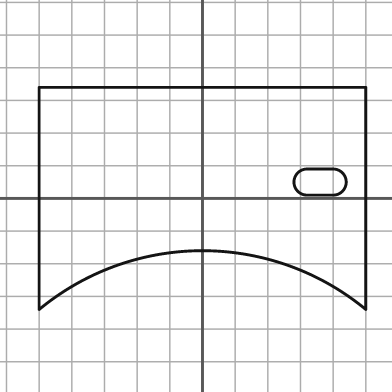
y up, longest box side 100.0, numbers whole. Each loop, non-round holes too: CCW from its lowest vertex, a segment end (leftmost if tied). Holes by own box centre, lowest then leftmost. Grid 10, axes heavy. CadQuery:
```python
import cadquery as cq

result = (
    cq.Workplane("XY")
    .moveTo(-50.0, -34.0)
    .threePointArc((0.0, -16.0), (50.0, -34.0))
    .lineTo(50.0, 34.0)
    .lineTo(-50.0, 34.0)
    .close()
    .moveTo(32.0, 1.0)
    .lineTo(40.0, 1.0)
    .threePointArc((44.0, 5.0), (40.0, 9.0))
    .lineTo(32.0, 9.0)
    .threePointArc((28.0, 5.0), (32.0, 1.0))
    .close()
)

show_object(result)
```